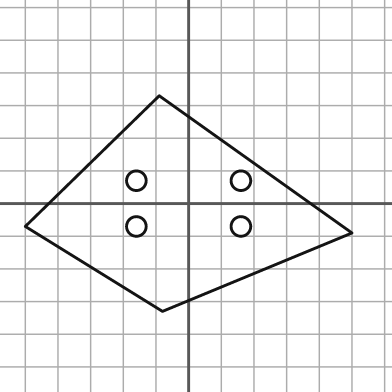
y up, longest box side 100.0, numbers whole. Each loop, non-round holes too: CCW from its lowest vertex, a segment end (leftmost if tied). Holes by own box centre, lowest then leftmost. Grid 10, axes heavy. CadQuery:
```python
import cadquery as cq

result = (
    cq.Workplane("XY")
    .moveTo(-8.0, -33.0)
    .lineTo(50.0, -9.0)
    .lineTo(-9.0, 33.0)
    .lineTo(-50.0, -7.0)
    .close()
    .moveTo(-16.0, -7.0)
    .circle(3.0)
    .moveTo(16.0, -7.0)
    .circle(3.0)
    .moveTo(-16.0, 7.0)
    .circle(3.0)
    .moveTo(16.0, 7.0)
    .circle(3.0)
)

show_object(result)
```